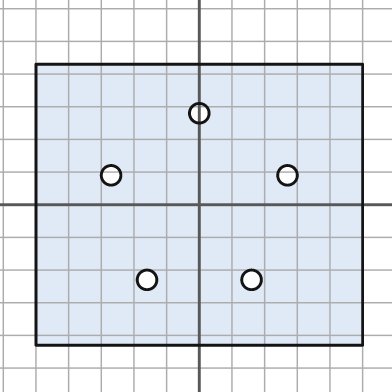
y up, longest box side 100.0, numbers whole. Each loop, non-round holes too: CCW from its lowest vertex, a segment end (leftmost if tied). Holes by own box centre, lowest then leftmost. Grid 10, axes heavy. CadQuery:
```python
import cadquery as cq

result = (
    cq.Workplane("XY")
    .moveTo(-50.0, -43.0)
    .lineTo(50.0, -43.0)
    .lineTo(50.0, 43.0)
    .lineTo(-50.0, 43.0)
    .close()
    .moveTo(-16.0, -23.0)
    .circle(3.0)
    .moveTo(16.0, -23.0)
    .circle(3.0)
    .moveTo(-27.0, 9.0)
    .circle(3.0)
    .moveTo(27.0, 9.0)
    .circle(3.0)
    .moveTo(0.0, 28.0)
    .circle(3.0)
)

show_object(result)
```